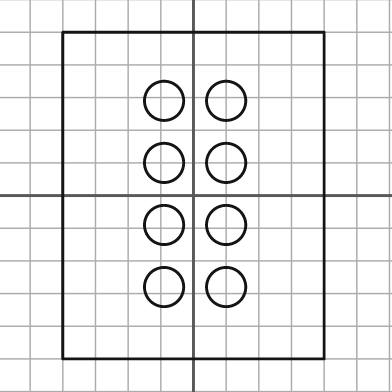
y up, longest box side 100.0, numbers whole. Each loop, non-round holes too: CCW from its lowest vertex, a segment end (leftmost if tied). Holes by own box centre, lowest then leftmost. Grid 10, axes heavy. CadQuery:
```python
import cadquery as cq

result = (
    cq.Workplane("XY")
    .moveTo(-40.0, -50.0)
    .lineTo(40.0, -50.0)
    .lineTo(40.0, 50.0)
    .lineTo(-40.0, 50.0)
    .close()
    .moveTo(-9.0, -28.0)
    .circle(6.0)
    .moveTo(10.0, -28.0)
    .circle(6.0)
    .moveTo(-9.0, -9.0)
    .circle(6.0)
    .moveTo(10.0, -9.0)
    .circle(6.0)
    .moveTo(-9.0, 10.0)
    .circle(6.0)
    .moveTo(10.0, 10.0)
    .circle(6.0)
    .moveTo(-9.0, 29.0)
    .circle(6.0)
    .moveTo(10.0, 29.0)
    .circle(6.0)
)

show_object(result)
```